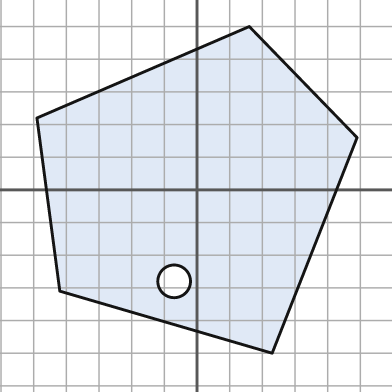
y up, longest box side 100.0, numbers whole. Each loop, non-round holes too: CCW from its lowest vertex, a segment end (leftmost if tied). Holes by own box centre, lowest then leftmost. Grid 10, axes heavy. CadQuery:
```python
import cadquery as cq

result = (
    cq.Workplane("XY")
    .moveTo(23.0, -50.0)
    .lineTo(49.0, 16.0)
    .lineTo(16.0, 50.0)
    .lineTo(-49.0, 22.0)
    .lineTo(-42.0, -31.0)
    .close()
    .moveTo(-7.0, -28.0)
    .circle(5.0)
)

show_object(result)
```